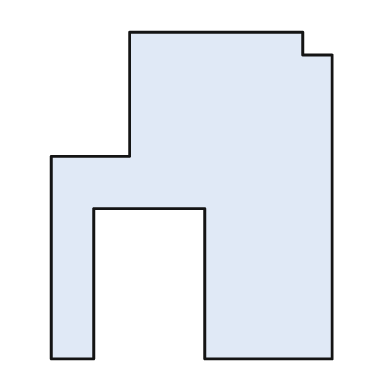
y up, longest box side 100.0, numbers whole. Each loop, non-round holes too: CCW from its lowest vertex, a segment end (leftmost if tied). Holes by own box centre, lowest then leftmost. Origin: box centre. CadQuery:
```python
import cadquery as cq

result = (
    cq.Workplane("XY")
    .moveTo(-43.0, -50.0)
    .lineTo(-30.0, -50.0)
    .lineTo(-30.0, -4.0)
    .lineTo(4.0, -4.0)
    .lineTo(4.0, -50.0)
    .lineTo(43.0, -50.0)
    .lineTo(43.0, 43.0)
    .lineTo(34.0, 43.0)
    .lineTo(34.0, 50.0)
    .lineTo(-19.0, 50.0)
    .lineTo(-19.0, 12.0)
    .lineTo(-43.0, 12.0)
    .close()
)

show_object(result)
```